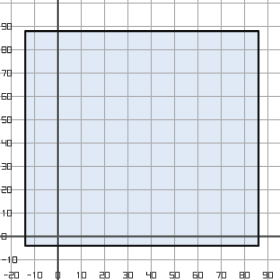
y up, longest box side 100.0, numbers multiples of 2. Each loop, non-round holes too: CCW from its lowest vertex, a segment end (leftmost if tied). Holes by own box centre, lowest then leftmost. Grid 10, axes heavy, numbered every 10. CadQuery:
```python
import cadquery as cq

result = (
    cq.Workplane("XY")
    .moveTo(-14.0, -4.0)
    .lineTo(86.0, -4.0)
    .lineTo(86.0, 88.0)
    .lineTo(-14.0, 88.0)
    .close()
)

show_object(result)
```